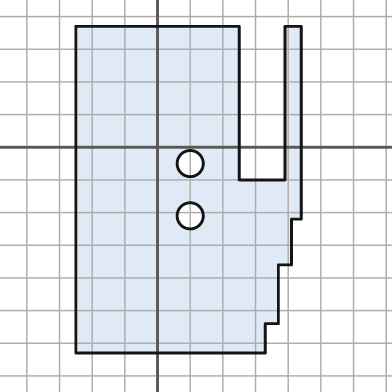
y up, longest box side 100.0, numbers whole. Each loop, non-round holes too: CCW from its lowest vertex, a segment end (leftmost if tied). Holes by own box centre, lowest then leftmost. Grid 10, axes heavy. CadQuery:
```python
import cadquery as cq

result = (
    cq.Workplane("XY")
    .moveTo(-25.0, -63.0)
    .lineTo(33.0, -63.0)
    .lineTo(33.0, -54.0)
    .lineTo(37.0, -54.0)
    .lineTo(37.0, -36.0)
    .lineTo(41.0, -36.0)
    .lineTo(41.0, -22.0)
    .lineTo(44.0, -22.0)
    .lineTo(44.0, 37.0)
    .lineTo(39.0, 37.0)
    .lineTo(39.0, -10.0)
    .lineTo(25.0, -10.0)
    .lineTo(25.0, 37.0)
    .lineTo(-25.0, 37.0)
    .close()
    .moveTo(10.0, -21.0)
    .circle(4.0)
    .moveTo(10.0, -5.0)
    .circle(4.0)
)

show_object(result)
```